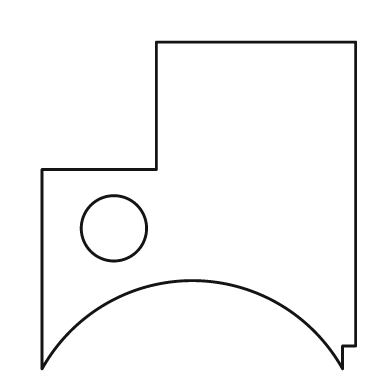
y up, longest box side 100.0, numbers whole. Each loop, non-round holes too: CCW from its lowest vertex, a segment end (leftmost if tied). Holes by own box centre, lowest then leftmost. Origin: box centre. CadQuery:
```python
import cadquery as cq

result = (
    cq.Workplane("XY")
    .moveTo(-48.0, -50.0)
    .threePointArc((-2.0, -23.0), (44.0, -50.0))
    .lineTo(44.0, -43.0)
    .lineTo(48.0, -43.0)
    .lineTo(48.0, 50.0)
    .lineTo(-13.0, 50.0)
    .lineTo(-13.0, 11.0)
    .lineTo(-48.0, 11.0)
    .close()
    .moveTo(-26.0, -7.0)
    .circle(10.0)
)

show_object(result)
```